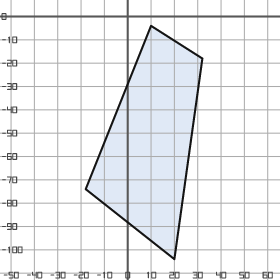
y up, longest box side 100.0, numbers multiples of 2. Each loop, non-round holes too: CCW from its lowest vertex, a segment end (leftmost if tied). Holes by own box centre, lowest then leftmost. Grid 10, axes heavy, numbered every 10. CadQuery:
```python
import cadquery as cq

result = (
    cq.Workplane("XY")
    .moveTo(20.0, -104.0)
    .lineTo(32.0, -18.0)
    .lineTo(10.0, -4.0)
    .lineTo(-18.0, -74.0)
    .close()
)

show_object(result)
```